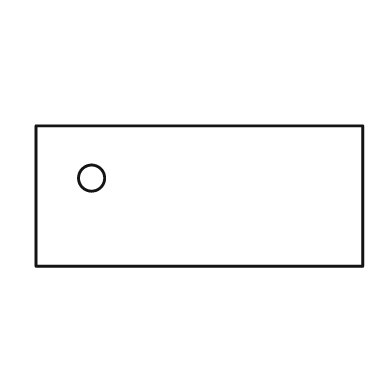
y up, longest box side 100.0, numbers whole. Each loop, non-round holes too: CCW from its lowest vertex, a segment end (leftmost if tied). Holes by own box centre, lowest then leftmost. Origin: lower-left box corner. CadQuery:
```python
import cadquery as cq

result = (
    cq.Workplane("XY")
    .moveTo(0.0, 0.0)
    .lineTo(100.0, 0.0)
    .lineTo(100.0, 43.0)
    .lineTo(0.0, 43.0)
    .close()
    .moveTo(17.0, 27.0)
    .circle(4.0)
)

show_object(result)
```